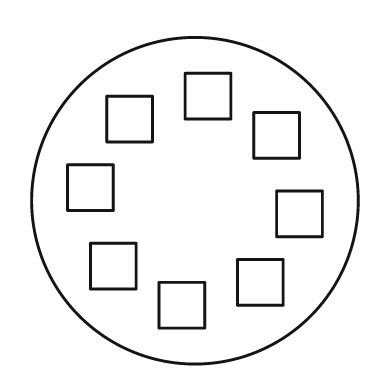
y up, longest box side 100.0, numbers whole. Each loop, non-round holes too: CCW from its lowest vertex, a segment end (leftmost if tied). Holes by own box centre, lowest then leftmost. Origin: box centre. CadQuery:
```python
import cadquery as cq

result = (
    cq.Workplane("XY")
    .moveTo(0.0, 0.0)
    .circle(50.0)
    .moveTo(-11.0, -39.0)
    .lineTo(3.0, -39.0)
    .lineTo(3.0, -25.0)
    .lineTo(-11.0, -25.0)
    .close()
    .moveTo(13.0, -32.0)
    .lineTo(27.0, -32.0)
    .lineTo(27.0, -18.0)
    .lineTo(13.0, -18.0)
    .close()
    .moveTo(-32.0, -27.0)
    .lineTo(-18.0, -27.0)
    .lineTo(-18.0, -13.0)
    .lineTo(-32.0, -13.0)
    .close()
    .moveTo(25.0, -11.0)
    .lineTo(39.0, -11.0)
    .lineTo(39.0, 3.0)
    .lineTo(25.0, 3.0)
    .close()
    .moveTo(-39.0, -3.0)
    .lineTo(-25.0, -3.0)
    .lineTo(-25.0, 11.0)
    .lineTo(-39.0, 11.0)
    .close()
    .moveTo(18.0, 13.0)
    .lineTo(32.0, 13.0)
    .lineTo(32.0, 27.0)
    .lineTo(18.0, 27.0)
    .close()
    .moveTo(-27.0, 18.0)
    .lineTo(-13.0, 18.0)
    .lineTo(-13.0, 32.0)
    .lineTo(-27.0, 32.0)
    .close()
    .moveTo(-3.0, 25.0)
    .lineTo(11.0, 25.0)
    .lineTo(11.0, 39.0)
    .lineTo(-3.0, 39.0)
    .close()
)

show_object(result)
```